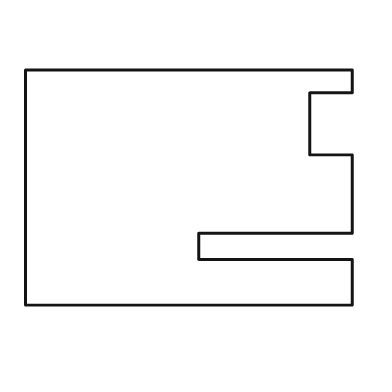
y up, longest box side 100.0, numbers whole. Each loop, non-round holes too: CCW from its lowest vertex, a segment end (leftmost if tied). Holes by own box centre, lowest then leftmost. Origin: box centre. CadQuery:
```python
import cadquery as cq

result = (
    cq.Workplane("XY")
    .moveTo(-50.0, -36.0)
    .lineTo(50.0, -36.0)
    .lineTo(50.0, -22.0)
    .lineTo(3.0, -22.0)
    .lineTo(3.0, -14.0)
    .lineTo(50.0, -14.0)
    .lineTo(50.0, 10.0)
    .lineTo(37.0, 10.0)
    .lineTo(37.0, 29.0)
    .lineTo(50.0, 29.0)
    .lineTo(50.0, 36.0)
    .lineTo(-50.0, 36.0)
    .close()
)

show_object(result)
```